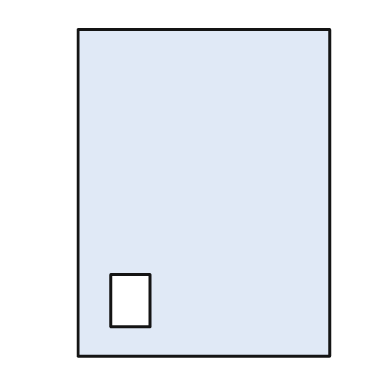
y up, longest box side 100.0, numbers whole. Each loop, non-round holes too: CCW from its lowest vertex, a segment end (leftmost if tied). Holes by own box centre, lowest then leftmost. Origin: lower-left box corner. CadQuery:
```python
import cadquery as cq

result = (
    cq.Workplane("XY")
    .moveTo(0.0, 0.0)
    .lineTo(77.0, 0.0)
    .lineTo(77.0, 100.0)
    .lineTo(0.0, 100.0)
    .close()
    .moveTo(10.0, 9.0)
    .lineTo(22.0, 9.0)
    .lineTo(22.0, 25.0)
    .lineTo(10.0, 25.0)
    .close()
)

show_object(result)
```